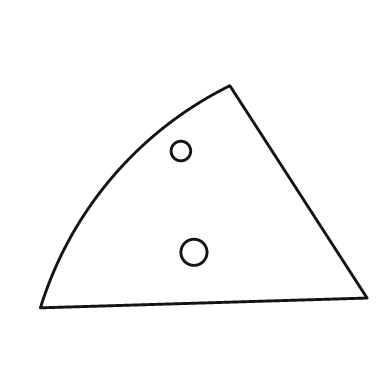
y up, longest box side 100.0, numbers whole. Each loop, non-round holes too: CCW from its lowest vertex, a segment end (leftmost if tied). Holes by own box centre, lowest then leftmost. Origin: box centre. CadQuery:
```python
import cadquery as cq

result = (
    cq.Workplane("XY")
    .moveTo(-50.0, -34.0)
    .lineTo(50.0, -31.0)
    .lineTo(8.0, 34.0)
    .threePointArc((-28.0, 6.0), (-50.0, -34.0))
    .close()
    .moveTo(-3.0, -17.0)
    .circle(4.0)
    .moveTo(-7.0, 14.0)
    .circle(3.0)
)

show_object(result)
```